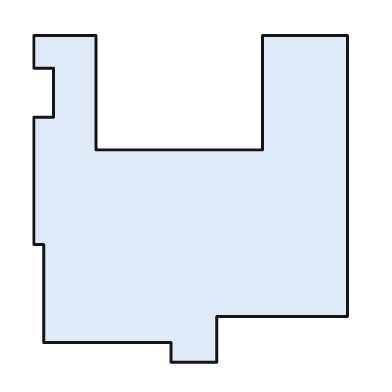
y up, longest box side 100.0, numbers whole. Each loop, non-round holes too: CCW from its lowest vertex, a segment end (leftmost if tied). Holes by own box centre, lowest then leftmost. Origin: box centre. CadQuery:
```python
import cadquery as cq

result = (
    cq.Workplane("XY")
    .moveTo(-6.0, -50.0)
    .lineTo(8.0, -50.0)
    .lineTo(8.0, -36.0)
    .lineTo(48.0, -36.0)
    .lineTo(48.0, 50.0)
    .lineTo(22.0, 50.0)
    .lineTo(22.0, 15.0)
    .lineTo(-29.0, 15.0)
    .lineTo(-29.0, 50.0)
    .lineTo(-48.0, 50.0)
    .lineTo(-48.0, 40.0)
    .lineTo(-42.0, 40.0)
    .lineTo(-42.0, 25.0)
    .lineTo(-48.0, 25.0)
    .lineTo(-48.0, -14.0)
    .lineTo(-45.0, -14.0)
    .lineTo(-45.0, -44.0)
    .lineTo(-6.0, -44.0)
    .close()
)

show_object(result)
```